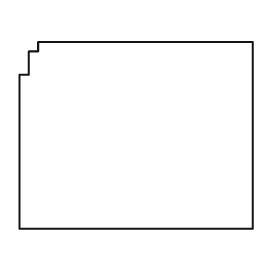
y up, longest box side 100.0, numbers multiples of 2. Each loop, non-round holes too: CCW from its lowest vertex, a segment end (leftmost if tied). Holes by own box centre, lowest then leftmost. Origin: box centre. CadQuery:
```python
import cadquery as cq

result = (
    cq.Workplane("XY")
    .moveTo(-50.0, -40.0)
    .lineTo(50.0, -40.0)
    .lineTo(50.0, 40.0)
    .lineTo(-42.0, 40.0)
    .lineTo(-42.0, 36.0)
    .lineTo(-46.0, 36.0)
    .lineTo(-46.0, 26.0)
    .lineTo(-50.0, 26.0)
    .close()
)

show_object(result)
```